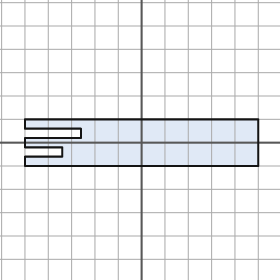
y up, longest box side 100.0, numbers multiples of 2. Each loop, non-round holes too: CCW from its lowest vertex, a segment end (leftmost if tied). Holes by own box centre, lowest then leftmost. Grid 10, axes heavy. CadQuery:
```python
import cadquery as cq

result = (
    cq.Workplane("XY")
    .moveTo(-50.0, -10.0)
    .lineTo(50.0, -10.0)
    .lineTo(50.0, 10.0)
    .lineTo(-50.0, 10.0)
    .lineTo(-50.0, 6.0)
    .lineTo(-26.0, 6.0)
    .lineTo(-26.0, 2.0)
    .lineTo(-50.0, 2.0)
    .lineTo(-50.0, -2.0)
    .lineTo(-34.0, -2.0)
    .lineTo(-34.0, -6.0)
    .lineTo(-50.0, -6.0)
    .close()
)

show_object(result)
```